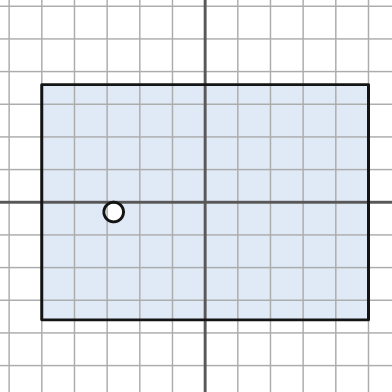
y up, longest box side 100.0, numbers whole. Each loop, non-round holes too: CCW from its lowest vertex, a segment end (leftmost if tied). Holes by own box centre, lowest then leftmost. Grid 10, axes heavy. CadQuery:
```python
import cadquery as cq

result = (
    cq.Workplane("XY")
    .moveTo(-50.0, -36.0)
    .lineTo(50.0, -36.0)
    .lineTo(50.0, 36.0)
    .lineTo(-50.0, 36.0)
    .close()
    .moveTo(-28.0, -3.0)
    .circle(3.0)
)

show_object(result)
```